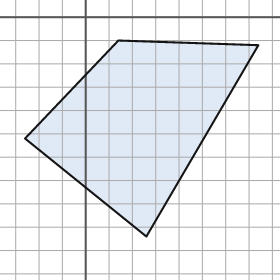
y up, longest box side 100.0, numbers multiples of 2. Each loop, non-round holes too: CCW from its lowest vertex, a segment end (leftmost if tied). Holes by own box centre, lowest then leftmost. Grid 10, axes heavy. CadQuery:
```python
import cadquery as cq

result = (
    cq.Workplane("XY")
    .moveTo(26.0, -94.0)
    .lineTo(74.0, -12.0)
    .lineTo(14.0, -10.0)
    .lineTo(-26.0, -52.0)
    .close()
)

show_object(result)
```